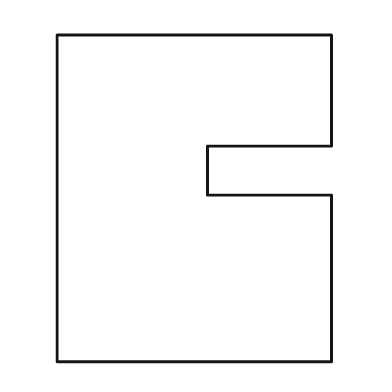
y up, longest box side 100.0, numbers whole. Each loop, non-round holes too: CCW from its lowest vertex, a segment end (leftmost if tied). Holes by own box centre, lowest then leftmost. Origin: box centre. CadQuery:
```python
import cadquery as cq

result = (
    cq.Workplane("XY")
    .moveTo(-42.0, -50.0)
    .lineTo(42.0, -50.0)
    .lineTo(42.0, 1.0)
    .lineTo(4.0, 1.0)
    .lineTo(4.0, 16.0)
    .lineTo(42.0, 16.0)
    .lineTo(42.0, 50.0)
    .lineTo(-42.0, 50.0)
    .close()
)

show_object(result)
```